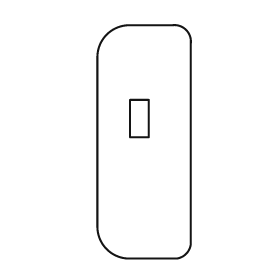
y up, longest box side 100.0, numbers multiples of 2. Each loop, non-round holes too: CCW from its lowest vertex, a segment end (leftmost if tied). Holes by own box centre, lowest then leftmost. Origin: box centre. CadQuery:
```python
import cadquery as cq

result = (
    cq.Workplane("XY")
    .moveTo(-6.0, -50.0)
    .lineTo(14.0, -50.0)
    .threePointArc((18.0, -48.0), (20.0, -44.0))
    .lineTo(20.0, 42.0)
    .threePointArc((18.0, 48.0), (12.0, 50.0))
    .lineTo(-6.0, 50.0)
    .threePointArc((-16.0, 46.0), (-20.0, 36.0))
    .lineTo(-20.0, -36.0)
    .threePointArc((-16.0, -46.0), (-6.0, -50.0))
    .close()
    .moveTo(-6.0, 2.0)
    .lineTo(2.0, 2.0)
    .lineTo(2.0, 18.0)
    .lineTo(-6.0, 18.0)
    .close()
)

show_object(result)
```